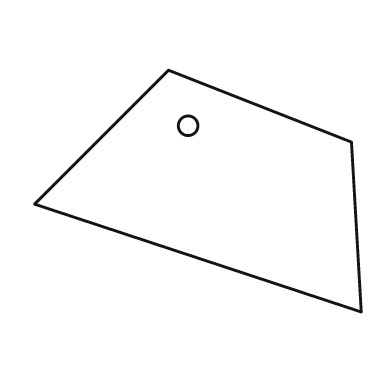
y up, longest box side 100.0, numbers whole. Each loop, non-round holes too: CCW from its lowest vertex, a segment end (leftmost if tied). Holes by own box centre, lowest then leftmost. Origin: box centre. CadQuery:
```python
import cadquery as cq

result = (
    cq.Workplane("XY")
    .moveTo(50.0, -37.0)
    .lineTo(47.0, 15.0)
    .lineTo(-9.0, 37.0)
    .lineTo(-50.0, -4.0)
    .close()
    .moveTo(-3.0, 20.0)
    .circle(3.0)
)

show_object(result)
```